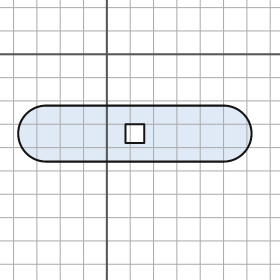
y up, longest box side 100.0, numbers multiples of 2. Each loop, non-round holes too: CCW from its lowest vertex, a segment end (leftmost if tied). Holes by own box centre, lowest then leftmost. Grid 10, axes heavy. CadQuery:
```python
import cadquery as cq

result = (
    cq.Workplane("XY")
    .moveTo(-26.0, -46.0)
    .lineTo(50.0, -46.0)
    .threePointArc((62.0, -34.0), (50.0, -22.0))
    .lineTo(-26.0, -22.0)
    .threePointArc((-38.0, -34.0), (-26.0, -46.0))
    .close()
    .moveTo(8.0, -38.0)
    .lineTo(16.0, -38.0)
    .lineTo(16.0, -30.0)
    .lineTo(8.0, -30.0)
    .close()
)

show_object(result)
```